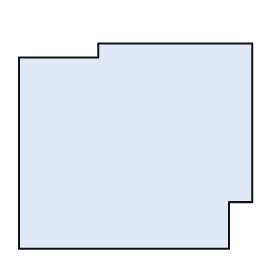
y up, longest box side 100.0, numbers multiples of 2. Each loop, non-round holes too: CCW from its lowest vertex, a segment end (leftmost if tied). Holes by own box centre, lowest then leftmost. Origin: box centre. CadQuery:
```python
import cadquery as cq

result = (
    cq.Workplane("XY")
    .moveTo(-50.0, -44.0)
    .lineTo(40.0, -44.0)
    .lineTo(40.0, -24.0)
    .lineTo(50.0, -24.0)
    .lineTo(50.0, 44.0)
    .lineTo(-16.0, 44.0)
    .lineTo(-16.0, 38.0)
    .lineTo(-50.0, 38.0)
    .close()
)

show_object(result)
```